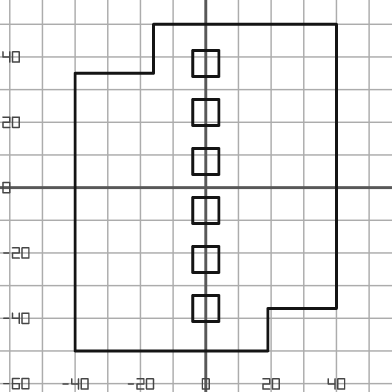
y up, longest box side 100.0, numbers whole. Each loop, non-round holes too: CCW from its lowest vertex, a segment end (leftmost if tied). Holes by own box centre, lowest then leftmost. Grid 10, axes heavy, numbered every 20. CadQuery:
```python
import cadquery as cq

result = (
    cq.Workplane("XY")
    .moveTo(-40.0, -50.0)
    .lineTo(19.0, -50.0)
    .lineTo(19.0, -37.0)
    .lineTo(40.0, -37.0)
    .lineTo(40.0, 50.0)
    .lineTo(-16.0, 50.0)
    .lineTo(-16.0, 35.0)
    .lineTo(-40.0, 35.0)
    .close()
    .moveTo(-4.0, -41.0)
    .lineTo(4.0, -41.0)
    .lineTo(4.0, -33.0)
    .lineTo(-4.0, -33.0)
    .close()
    .moveTo(-4.0, -26.0)
    .lineTo(4.0, -26.0)
    .lineTo(4.0, -18.0)
    .lineTo(-4.0, -18.0)
    .close()
    .moveTo(-4.0, -11.0)
    .lineTo(4.0, -11.0)
    .lineTo(4.0, -3.0)
    .lineTo(-4.0, -3.0)
    .close()
    .moveTo(-4.0, 4.0)
    .lineTo(4.0, 4.0)
    .lineTo(4.0, 12.0)
    .lineTo(-4.0, 12.0)
    .close()
    .moveTo(-4.0, 19.0)
    .lineTo(4.0, 19.0)
    .lineTo(4.0, 27.0)
    .lineTo(-4.0, 27.0)
    .close()
    .moveTo(-4.0, 34.0)
    .lineTo(4.0, 34.0)
    .lineTo(4.0, 42.0)
    .lineTo(-4.0, 42.0)
    .close()
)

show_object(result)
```